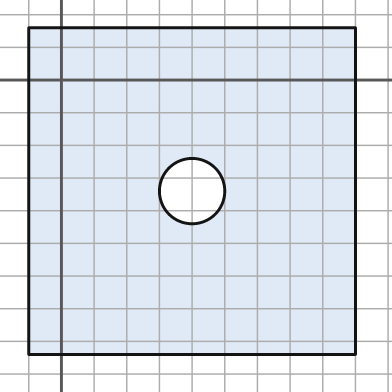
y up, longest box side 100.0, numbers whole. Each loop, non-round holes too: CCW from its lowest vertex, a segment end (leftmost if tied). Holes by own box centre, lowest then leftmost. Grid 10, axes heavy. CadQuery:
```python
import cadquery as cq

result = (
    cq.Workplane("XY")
    .moveTo(-10.0, -84.0)
    .lineTo(90.0, -84.0)
    .lineTo(90.0, 16.0)
    .lineTo(-10.0, 16.0)
    .close()
    .moveTo(40.0, -34.0)
    .circle(10.0)
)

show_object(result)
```